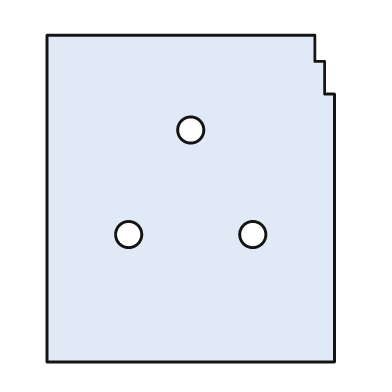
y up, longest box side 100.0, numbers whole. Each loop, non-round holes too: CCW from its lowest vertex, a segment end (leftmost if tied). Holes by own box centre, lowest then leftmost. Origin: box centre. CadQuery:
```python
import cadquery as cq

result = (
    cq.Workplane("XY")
    .moveTo(-44.0, -50.0)
    .lineTo(44.0, -50.0)
    .lineTo(44.0, 32.0)
    .lineTo(41.0, 32.0)
    .lineTo(41.0, 42.0)
    .lineTo(38.0, 42.0)
    .lineTo(38.0, 50.0)
    .lineTo(-44.0, 50.0)
    .close()
    .moveTo(-19.0, -11.0)
    .circle(4.0)
    .moveTo(19.0, -11.0)
    .circle(4.0)
    .moveTo(0.0, 21.0)
    .circle(4.0)
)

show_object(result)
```